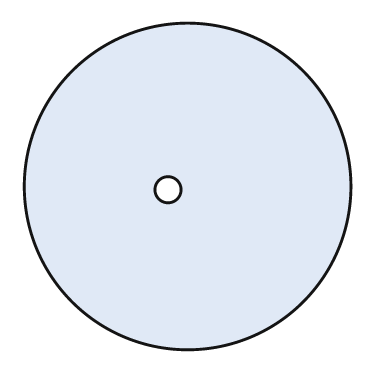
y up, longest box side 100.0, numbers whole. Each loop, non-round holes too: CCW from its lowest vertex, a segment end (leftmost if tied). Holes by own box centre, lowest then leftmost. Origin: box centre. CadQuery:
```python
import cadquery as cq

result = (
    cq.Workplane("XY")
    .moveTo(0.0, 0.0)
    .circle(50.0)
    .moveTo(-6.0, -1.0)
    .circle(4.0)
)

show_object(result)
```